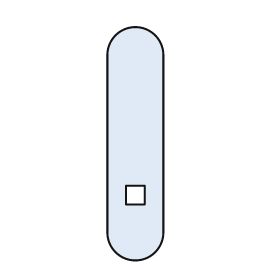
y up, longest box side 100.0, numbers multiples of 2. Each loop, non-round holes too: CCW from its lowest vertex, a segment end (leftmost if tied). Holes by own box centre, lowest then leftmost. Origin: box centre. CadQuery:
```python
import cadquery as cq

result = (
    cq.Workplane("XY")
    .moveTo(-12.0, -38.0)
    .threePointArc((0.0, -50.0), (12.0, -38.0))
    .lineTo(12.0, 38.0)
    .threePointArc((0.0, 50.0), (-12.0, 38.0))
    .close()
    .moveTo(-4.0, -26.0)
    .lineTo(4.0, -26.0)
    .lineTo(4.0, -18.0)
    .lineTo(-4.0, -18.0)
    .close()
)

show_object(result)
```